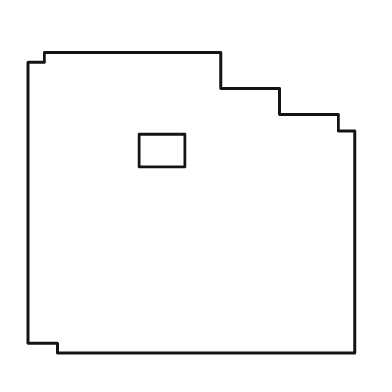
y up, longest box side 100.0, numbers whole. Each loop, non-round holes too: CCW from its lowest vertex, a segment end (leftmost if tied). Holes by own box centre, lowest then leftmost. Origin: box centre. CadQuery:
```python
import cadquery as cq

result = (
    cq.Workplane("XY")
    .moveTo(-41.0, -46.0)
    .lineTo(50.0, -46.0)
    .lineTo(50.0, 22.0)
    .lineTo(45.0, 22.0)
    .lineTo(45.0, 27.0)
    .lineTo(27.0, 27.0)
    .lineTo(27.0, 35.0)
    .lineTo(9.0, 35.0)
    .lineTo(9.0, 46.0)
    .lineTo(-45.0, 46.0)
    .lineTo(-45.0, 43.0)
    .lineTo(-50.0, 43.0)
    .lineTo(-50.0, -43.0)
    .lineTo(-41.0, -43.0)
    .close()
    .moveTo(-16.0, 11.0)
    .lineTo(-2.0, 11.0)
    .lineTo(-2.0, 21.0)
    .lineTo(-16.0, 21.0)
    .close()
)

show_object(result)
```